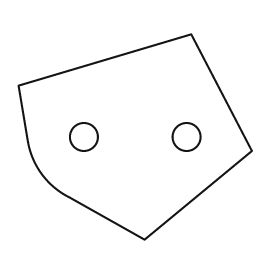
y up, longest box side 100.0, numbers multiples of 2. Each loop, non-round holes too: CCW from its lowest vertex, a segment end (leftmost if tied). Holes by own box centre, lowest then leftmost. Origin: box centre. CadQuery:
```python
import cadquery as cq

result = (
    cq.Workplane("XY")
    .moveTo(4.0, -44.0)
    .lineTo(50.0, -6.0)
    .lineTo(24.0, 44.0)
    .lineTo(-50.0, 22.0)
    .lineTo(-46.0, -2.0)
    .threePointArc((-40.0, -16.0), (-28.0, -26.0))
    .close()
    .moveTo(-22.0, 0.0)
    .circle(6.0)
    .moveTo(22.0, 0.0)
    .circle(6.0)
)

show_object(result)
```